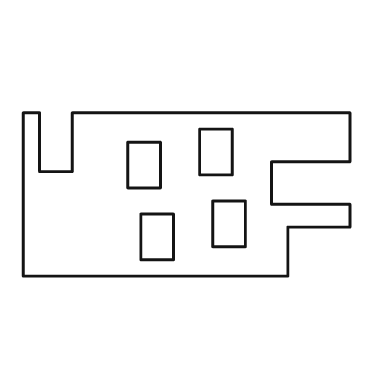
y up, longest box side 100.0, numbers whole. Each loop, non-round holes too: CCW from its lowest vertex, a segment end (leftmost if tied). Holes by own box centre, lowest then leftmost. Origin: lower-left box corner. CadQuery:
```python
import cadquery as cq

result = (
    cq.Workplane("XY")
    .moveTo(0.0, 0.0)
    .lineTo(81.0, 0.0)
    .lineTo(81.0, 15.0)
    .lineTo(100.0, 15.0)
    .lineTo(100.0, 22.0)
    .lineTo(76.0, 22.0)
    .lineTo(76.0, 35.0)
    .lineTo(100.0, 35.0)
    .lineTo(100.0, 50.0)
    .lineTo(15.0, 50.0)
    .lineTo(15.0, 32.0)
    .lineTo(5.0, 32.0)
    .lineTo(5.0, 50.0)
    .lineTo(0.0, 50.0)
    .close()
    .moveTo(36.0, 5.0)
    .lineTo(46.0, 5.0)
    .lineTo(46.0, 19.0)
    .lineTo(36.0, 19.0)
    .close()
    .moveTo(58.0, 9.0)
    .lineTo(68.0, 9.0)
    .lineTo(68.0, 23.0)
    .lineTo(58.0, 23.0)
    .close()
    .moveTo(32.0, 27.0)
    .lineTo(42.0, 27.0)
    .lineTo(42.0, 41.0)
    .lineTo(32.0, 41.0)
    .close()
    .moveTo(54.0, 31.0)
    .lineTo(64.0, 31.0)
    .lineTo(64.0, 45.0)
    .lineTo(54.0, 45.0)
    .close()
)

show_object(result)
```